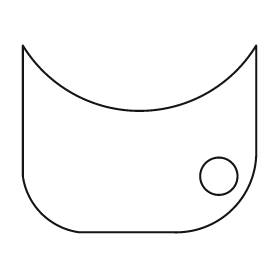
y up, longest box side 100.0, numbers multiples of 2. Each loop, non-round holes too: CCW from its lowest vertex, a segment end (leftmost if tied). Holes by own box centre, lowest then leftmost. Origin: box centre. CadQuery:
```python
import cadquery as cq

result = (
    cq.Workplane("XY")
    .moveTo(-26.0, -40.0)
    .lineTo(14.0, -40.0)
    .threePointArc((40.0, -30.0), (50.0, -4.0))
    .lineTo(50.0, 40.0)
    .threePointArc((0.0, 12.0), (-50.0, 40.0))
    .lineTo(-50.0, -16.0)
    .threePointArc((-42.0, -32.0), (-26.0, -40.0))
    .close()
    .moveTo(34.0, -16.0)
    .circle(8.0)
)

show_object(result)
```